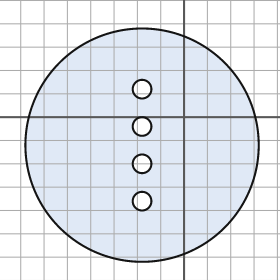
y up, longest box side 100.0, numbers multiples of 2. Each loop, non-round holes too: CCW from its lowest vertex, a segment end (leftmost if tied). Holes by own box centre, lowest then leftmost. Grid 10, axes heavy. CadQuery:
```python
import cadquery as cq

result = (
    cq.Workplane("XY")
    .moveTo(-18.0, -12.0)
    .circle(50.0)
    .moveTo(-18.0, -36.0)
    .circle(4.0)
    .moveTo(-18.0, -20.0)
    .circle(4.0)
    .moveTo(-18.0, -4.0)
    .circle(4.0)
    .moveTo(-18.0, 12.0)
    .circle(4.0)
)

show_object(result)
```